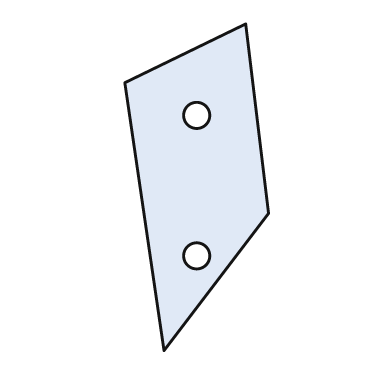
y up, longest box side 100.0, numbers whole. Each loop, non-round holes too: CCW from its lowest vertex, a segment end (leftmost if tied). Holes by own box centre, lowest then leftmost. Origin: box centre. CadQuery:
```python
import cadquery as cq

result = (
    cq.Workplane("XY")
    .moveTo(-10.0, -50.0)
    .lineTo(22.0, -8.0)
    .lineTo(15.0, 50.0)
    .lineTo(-22.0, 32.0)
    .close()
    .moveTo(0.0, -21.0)
    .circle(4.0)
    .moveTo(0.0, 22.0)
    .circle(4.0)
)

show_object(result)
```